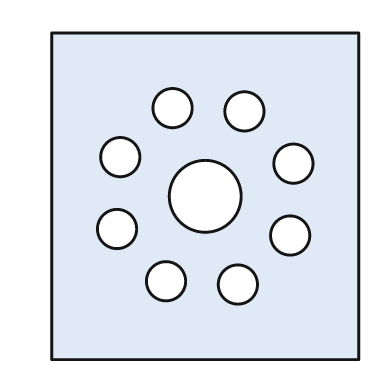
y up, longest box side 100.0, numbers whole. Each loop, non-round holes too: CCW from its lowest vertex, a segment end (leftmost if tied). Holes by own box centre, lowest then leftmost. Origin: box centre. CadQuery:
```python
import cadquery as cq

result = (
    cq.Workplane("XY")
    .moveTo(-47.0, -50.0)
    .lineTo(47.0, -50.0)
    .lineTo(47.0, 50.0)
    .lineTo(-47.0, 50.0)
    .close()
    .moveTo(10.0, -27.0)
    .circle(6.0)
    .moveTo(-12.0, -26.0)
    .circle(6.0)
    .moveTo(26.0, -12.0)
    .circle(6.0)
    .moveTo(-27.0, -10.0)
    .circle(6.0)
    .moveTo(0.0, 0.0)
    .circle(11.0)
    .moveTo(27.0, 10.0)
    .circle(6.0)
    .moveTo(-26.0, 12.0)
    .circle(6.0)
    .moveTo(12.0, 26.0)
    .circle(6.0)
    .moveTo(-10.0, 27.0)
    .circle(6.0)
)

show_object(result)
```